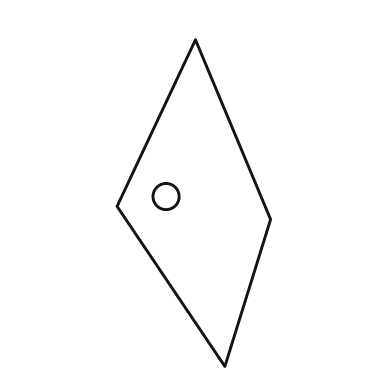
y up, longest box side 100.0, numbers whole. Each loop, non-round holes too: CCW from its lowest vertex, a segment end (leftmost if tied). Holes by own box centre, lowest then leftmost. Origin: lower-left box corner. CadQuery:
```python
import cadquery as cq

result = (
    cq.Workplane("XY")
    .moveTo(33.0, 0.0)
    .lineTo(47.0, 45.0)
    .lineTo(24.0, 100.0)
    .lineTo(0.0, 49.0)
    .close()
    .moveTo(15.0, 52.0)
    .circle(4.0)
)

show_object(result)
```